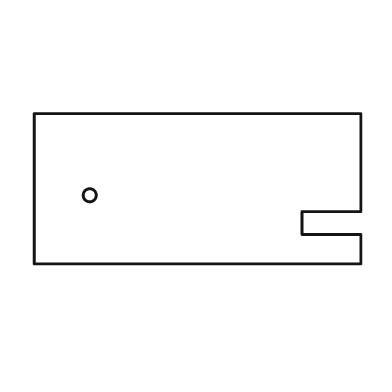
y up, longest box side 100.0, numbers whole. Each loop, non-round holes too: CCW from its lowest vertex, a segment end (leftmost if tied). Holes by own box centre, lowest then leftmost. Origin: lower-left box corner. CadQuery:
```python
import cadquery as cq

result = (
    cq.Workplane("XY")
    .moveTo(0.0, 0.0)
    .lineTo(100.0, 0.0)
    .lineTo(100.0, 9.0)
    .lineTo(82.0, 9.0)
    .lineTo(82.0, 16.0)
    .lineTo(100.0, 16.0)
    .lineTo(100.0, 46.0)
    .lineTo(0.0, 46.0)
    .close()
    .moveTo(17.0, 21.0)
    .circle(2.0)
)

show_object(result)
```